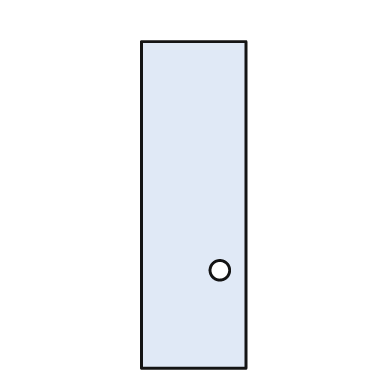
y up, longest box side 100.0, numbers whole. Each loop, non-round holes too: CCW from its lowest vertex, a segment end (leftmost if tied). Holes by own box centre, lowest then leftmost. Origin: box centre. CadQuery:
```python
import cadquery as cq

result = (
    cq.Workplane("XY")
    .moveTo(-16.0, -50.0)
    .lineTo(16.0, -50.0)
    .lineTo(16.0, 50.0)
    .lineTo(-16.0, 50.0)
    .close()
    .moveTo(8.0, -20.0)
    .circle(3.0)
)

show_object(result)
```